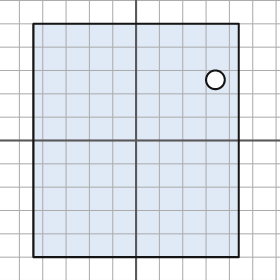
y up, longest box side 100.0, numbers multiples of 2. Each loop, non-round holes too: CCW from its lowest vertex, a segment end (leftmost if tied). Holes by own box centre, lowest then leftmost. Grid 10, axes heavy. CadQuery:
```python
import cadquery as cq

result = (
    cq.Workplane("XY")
    .moveTo(-44.0, -50.0)
    .lineTo(44.0, -50.0)
    .lineTo(44.0, 50.0)
    .lineTo(-44.0, 50.0)
    .close()
    .moveTo(34.0, 26.0)
    .circle(4.0)
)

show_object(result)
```